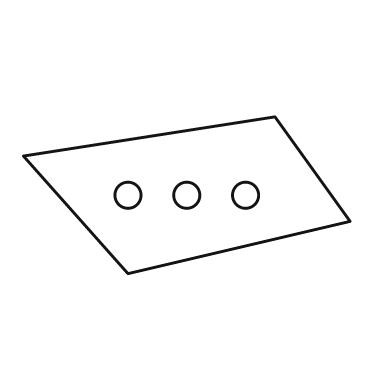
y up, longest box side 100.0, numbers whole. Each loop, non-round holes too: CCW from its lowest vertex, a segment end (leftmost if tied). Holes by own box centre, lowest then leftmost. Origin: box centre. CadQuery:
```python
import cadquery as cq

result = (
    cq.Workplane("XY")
    .moveTo(-18.0, -24.0)
    .lineTo(50.0, -8.0)
    .lineTo(27.0, 24.0)
    .lineTo(-50.0, 12.0)
    .close()
    .moveTo(-18.0, 0.0)
    .circle(4.0)
    .moveTo(0.0, 0.0)
    .circle(4.0)
    .moveTo(18.0, 0.0)
    .circle(4.0)
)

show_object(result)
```